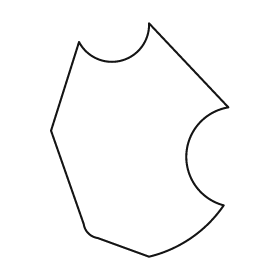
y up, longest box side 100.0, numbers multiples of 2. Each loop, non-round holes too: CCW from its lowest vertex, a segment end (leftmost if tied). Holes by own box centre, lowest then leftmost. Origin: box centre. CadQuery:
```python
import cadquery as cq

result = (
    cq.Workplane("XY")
    .moveTo(4.0, -50.0)
    .threePointArc((22.0, -42.0), (36.0, -28.0))
    .threePointArc((20.0, -6.0), (38.0, 14.0))
    .lineTo(4.0, 50.0)
    .threePointArc((-8.0, 34.0), (-26.0, 42.0))
    .lineTo(-38.0, 4.0)
    .lineTo(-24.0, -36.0)
    .threePointArc((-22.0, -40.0), (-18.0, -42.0))
    .close()
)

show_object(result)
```